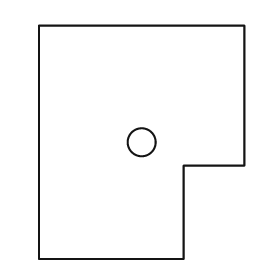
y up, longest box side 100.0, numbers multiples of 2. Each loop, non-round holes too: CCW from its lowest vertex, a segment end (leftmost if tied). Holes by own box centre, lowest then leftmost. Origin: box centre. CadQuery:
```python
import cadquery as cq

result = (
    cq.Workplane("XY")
    .moveTo(-44.0, -50.0)
    .lineTo(18.0, -50.0)
    .lineTo(18.0, -10.0)
    .lineTo(44.0, -10.0)
    .lineTo(44.0, 50.0)
    .lineTo(-44.0, 50.0)
    .close()
    .moveTo(0.0, 0.0)
    .circle(6.0)
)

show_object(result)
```